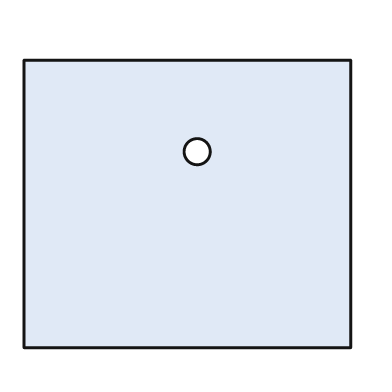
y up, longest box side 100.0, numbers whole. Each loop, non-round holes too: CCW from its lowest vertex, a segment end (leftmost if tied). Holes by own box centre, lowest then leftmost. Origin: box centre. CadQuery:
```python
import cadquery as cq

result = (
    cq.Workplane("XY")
    .moveTo(-50.0, -44.0)
    .lineTo(50.0, -44.0)
    .lineTo(50.0, 44.0)
    .lineTo(-50.0, 44.0)
    .close()
    .moveTo(3.0, 16.0)
    .circle(4.0)
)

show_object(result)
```